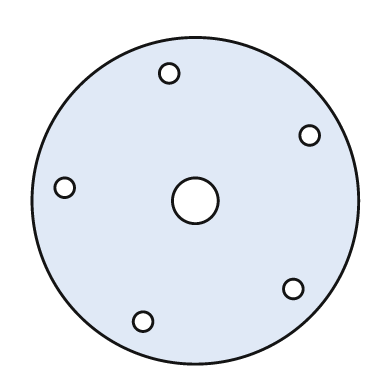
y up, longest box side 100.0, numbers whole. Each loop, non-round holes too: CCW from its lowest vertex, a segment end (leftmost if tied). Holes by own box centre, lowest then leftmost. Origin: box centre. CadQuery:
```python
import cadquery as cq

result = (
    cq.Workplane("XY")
    .moveTo(0.0, 0.0)
    .circle(50.0)
    .moveTo(-16.0, -37.0)
    .circle(3.0)
    .moveTo(30.0, -27.0)
    .circle(3.0)
    .moveTo(0.0, 0.0)
    .circle(7.0)
    .moveTo(-40.0, 4.0)
    .circle(3.0)
    .moveTo(35.0, 20.0)
    .circle(3.0)
    .moveTo(-8.0, 39.0)
    .circle(3.0)
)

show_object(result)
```